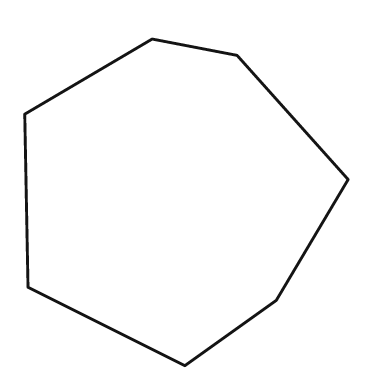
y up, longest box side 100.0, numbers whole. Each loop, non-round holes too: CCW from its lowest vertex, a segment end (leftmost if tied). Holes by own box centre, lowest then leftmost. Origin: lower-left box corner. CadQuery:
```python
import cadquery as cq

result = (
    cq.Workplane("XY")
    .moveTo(49.0, 0.0)
    .lineTo(77.0, 20.0)
    .lineTo(99.0, 57.0)
    .lineTo(65.0, 95.0)
    .lineTo(39.0, 100.0)
    .lineTo(0.0, 77.0)
    .lineTo(1.0, 24.0)
    .close()
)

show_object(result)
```